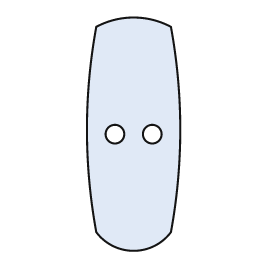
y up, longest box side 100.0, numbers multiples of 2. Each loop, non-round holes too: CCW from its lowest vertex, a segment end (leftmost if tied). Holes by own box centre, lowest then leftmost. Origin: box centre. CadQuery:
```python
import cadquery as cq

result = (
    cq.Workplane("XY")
    .moveTo(-16.0, -42.0)
    .threePointArc((0.0, -50.0), (16.0, -42.0))
    .threePointArc((20.0, 2.0), (16.0, 46.0))
    .threePointArc((0.0, 50.0), (-16.0, 46.0))
    .threePointArc((-20.0, 2.0), (-16.0, -42.0))
    .close()
    .moveTo(-8.0, 0.0)
    .circle(4.0)
    .moveTo(8.0, 0.0)
    .circle(4.0)
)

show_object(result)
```